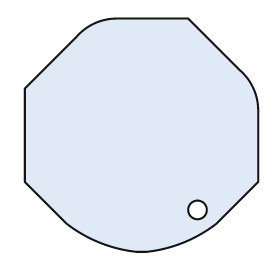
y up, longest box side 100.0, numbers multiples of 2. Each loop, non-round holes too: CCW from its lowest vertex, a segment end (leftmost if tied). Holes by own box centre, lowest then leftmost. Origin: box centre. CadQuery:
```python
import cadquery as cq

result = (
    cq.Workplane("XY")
    .moveTo(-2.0, -50.0)
    .lineTo(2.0, -50.0)
    .threePointArc((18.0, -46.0), (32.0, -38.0))
    .lineTo(50.0, -20.0)
    .lineTo(50.0, 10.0)
    .threePointArc((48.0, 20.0), (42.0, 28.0))
    .lineTo(20.0, 50.0)
    .lineTo(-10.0, 50.0)
    .threePointArc((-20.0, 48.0), (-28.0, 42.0))
    .lineTo(-50.0, 20.0)
    .lineTo(-50.0, -20.0)
    .lineTo(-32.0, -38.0)
    .threePointArc((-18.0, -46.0), (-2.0, -50.0))
    .close()
    .moveTo(24.0, -32.0)
    .circle(4.0)
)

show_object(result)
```